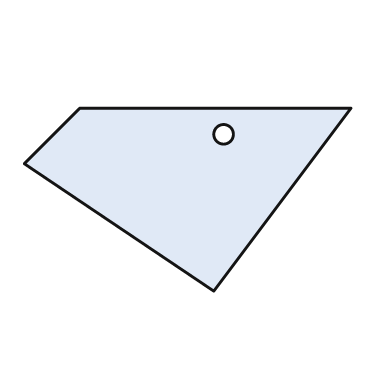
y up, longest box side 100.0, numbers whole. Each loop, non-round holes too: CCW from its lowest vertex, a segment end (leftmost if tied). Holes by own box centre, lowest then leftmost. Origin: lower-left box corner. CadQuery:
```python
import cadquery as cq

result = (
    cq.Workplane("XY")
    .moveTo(58.0, 0.0)
    .lineTo(100.0, 56.0)
    .lineTo(17.0, 56.0)
    .lineTo(0.0, 39.0)
    .close()
    .moveTo(61.0, 48.0)
    .circle(3.0)
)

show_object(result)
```